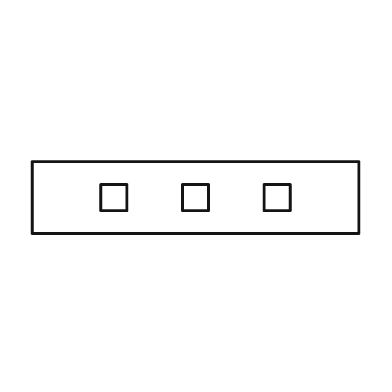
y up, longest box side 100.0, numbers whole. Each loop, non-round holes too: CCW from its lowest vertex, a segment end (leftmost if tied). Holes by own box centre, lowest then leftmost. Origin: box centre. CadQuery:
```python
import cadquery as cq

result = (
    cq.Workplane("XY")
    .moveTo(-50.0, -11.0)
    .lineTo(50.0, -11.0)
    .lineTo(50.0, 11.0)
    .lineTo(-50.0, 11.0)
    .close()
    .moveTo(-29.0, -4.0)
    .lineTo(-21.0, -4.0)
    .lineTo(-21.0, 4.0)
    .lineTo(-29.0, 4.0)
    .close()
    .moveTo(-4.0, -4.0)
    .lineTo(4.0, -4.0)
    .lineTo(4.0, 4.0)
    .lineTo(-4.0, 4.0)
    .close()
    .moveTo(21.0, -4.0)
    .lineTo(29.0, -4.0)
    .lineTo(29.0, 4.0)
    .lineTo(21.0, 4.0)
    .close()
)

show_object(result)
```